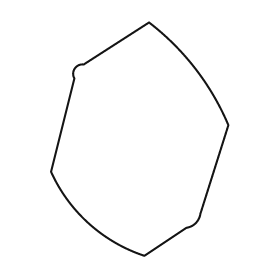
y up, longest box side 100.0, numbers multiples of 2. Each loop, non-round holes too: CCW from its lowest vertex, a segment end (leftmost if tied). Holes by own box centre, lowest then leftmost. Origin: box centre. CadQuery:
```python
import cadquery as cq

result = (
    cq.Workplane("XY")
    .moveTo(2.0, -50.0)
    .lineTo(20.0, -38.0)
    .threePointArc((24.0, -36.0), (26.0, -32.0))
    .lineTo(38.0, 6.0)
    .threePointArc((24.0, 30.0), (4.0, 50.0))
    .lineTo(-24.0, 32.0)
    .threePointArc((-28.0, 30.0), (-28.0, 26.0))
    .lineTo(-38.0, -14.0)
    .threePointArc((-22.0, -36.0), (2.0, -50.0))
    .close()
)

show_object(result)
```